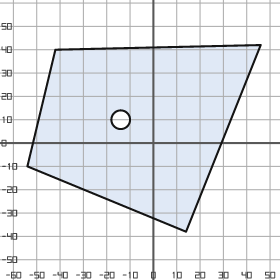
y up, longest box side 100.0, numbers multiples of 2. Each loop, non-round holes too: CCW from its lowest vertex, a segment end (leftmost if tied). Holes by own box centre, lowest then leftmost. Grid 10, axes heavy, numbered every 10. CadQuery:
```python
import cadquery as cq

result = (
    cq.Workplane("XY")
    .moveTo(14.0, -38.0)
    .lineTo(46.0, 42.0)
    .lineTo(-42.0, 40.0)
    .lineTo(-54.0, -10.0)
    .close()
    .moveTo(-14.0, 10.0)
    .circle(4.0)
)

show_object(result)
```